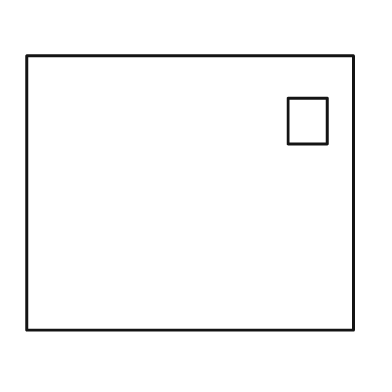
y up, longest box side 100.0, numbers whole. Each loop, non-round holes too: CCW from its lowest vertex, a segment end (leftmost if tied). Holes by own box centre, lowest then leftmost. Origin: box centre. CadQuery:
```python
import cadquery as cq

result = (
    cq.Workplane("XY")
    .moveTo(-50.0, -42.0)
    .lineTo(50.0, -42.0)
    .lineTo(50.0, 42.0)
    .lineTo(-50.0, 42.0)
    .close()
    .moveTo(30.0, 15.0)
    .lineTo(42.0, 15.0)
    .lineTo(42.0, 29.0)
    .lineTo(30.0, 29.0)
    .close()
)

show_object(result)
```